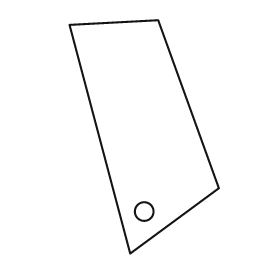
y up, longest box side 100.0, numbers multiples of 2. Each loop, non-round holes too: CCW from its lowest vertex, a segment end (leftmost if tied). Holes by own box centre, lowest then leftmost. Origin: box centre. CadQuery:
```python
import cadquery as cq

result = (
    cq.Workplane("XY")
    .moveTo(-6.0, -50.0)
    .lineTo(32.0, -22.0)
    .lineTo(6.0, 50.0)
    .lineTo(-32.0, 48.0)
    .close()
    .moveTo(0.0, -32.0)
    .circle(4.0)
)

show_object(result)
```